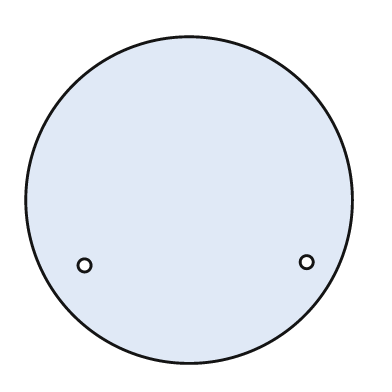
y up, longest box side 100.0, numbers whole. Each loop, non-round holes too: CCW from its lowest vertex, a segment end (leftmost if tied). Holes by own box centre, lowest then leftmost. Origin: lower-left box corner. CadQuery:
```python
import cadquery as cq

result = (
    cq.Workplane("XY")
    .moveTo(50.0, 50.0)
    .circle(50.0)
    .moveTo(18.0, 30.0)
    .circle(2.0)
    .moveTo(86.0, 31.0)
    .circle(2.0)
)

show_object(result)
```